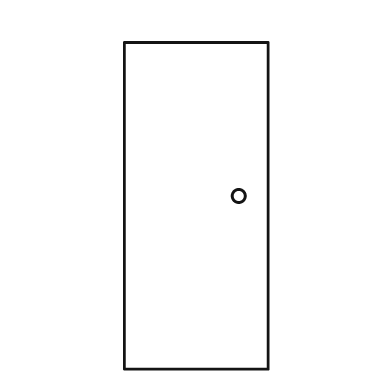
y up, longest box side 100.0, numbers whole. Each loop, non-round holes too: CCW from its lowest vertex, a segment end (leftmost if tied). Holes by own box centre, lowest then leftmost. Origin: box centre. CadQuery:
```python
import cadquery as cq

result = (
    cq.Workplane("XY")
    .moveTo(-22.0, -50.0)
    .lineTo(22.0, -50.0)
    .lineTo(22.0, 50.0)
    .lineTo(-22.0, 50.0)
    .close()
    .moveTo(13.0, 3.0)
    .circle(2.0)
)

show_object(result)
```